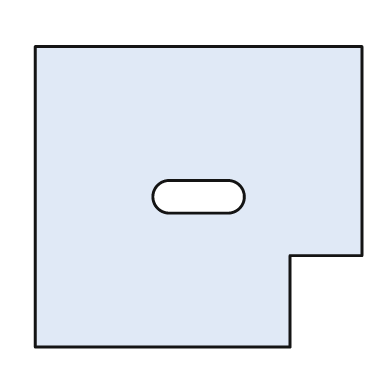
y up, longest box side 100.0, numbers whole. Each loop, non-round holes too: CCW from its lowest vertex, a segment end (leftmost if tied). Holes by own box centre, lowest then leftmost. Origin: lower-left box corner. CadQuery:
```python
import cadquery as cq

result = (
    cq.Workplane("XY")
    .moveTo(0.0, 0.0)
    .lineTo(78.0, 0.0)
    .lineTo(78.0, 28.0)
    .lineTo(100.0, 28.0)
    .lineTo(100.0, 92.0)
    .lineTo(0.0, 92.0)
    .close()
    .moveTo(41.0, 41.0)
    .lineTo(59.0, 41.0)
    .threePointArc((64.0, 46.0), (59.0, 51.0))
    .lineTo(41.0, 51.0)
    .threePointArc((36.0, 46.0), (41.0, 41.0))
    .close()
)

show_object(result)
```